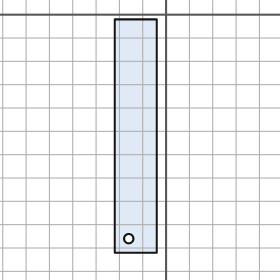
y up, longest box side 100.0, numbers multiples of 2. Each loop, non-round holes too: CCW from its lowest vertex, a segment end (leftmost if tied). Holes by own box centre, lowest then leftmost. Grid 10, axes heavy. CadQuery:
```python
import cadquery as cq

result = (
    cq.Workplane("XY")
    .moveTo(-22.0, -102.0)
    .lineTo(-4.0, -102.0)
    .lineTo(-4.0, -2.0)
    .lineTo(-22.0, -2.0)
    .close()
    .moveTo(-16.0, -96.0)
    .circle(2.0)
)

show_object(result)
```